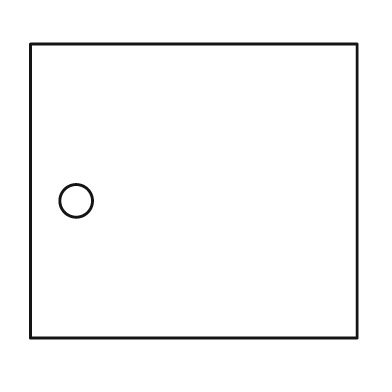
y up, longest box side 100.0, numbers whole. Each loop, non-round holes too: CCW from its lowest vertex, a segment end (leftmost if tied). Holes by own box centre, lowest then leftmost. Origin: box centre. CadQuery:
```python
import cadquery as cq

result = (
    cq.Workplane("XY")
    .moveTo(-50.0, -45.0)
    .lineTo(50.0, -45.0)
    .lineTo(50.0, 45.0)
    .lineTo(-50.0, 45.0)
    .close()
    .moveTo(-36.0, -3.0)
    .circle(5.0)
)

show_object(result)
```